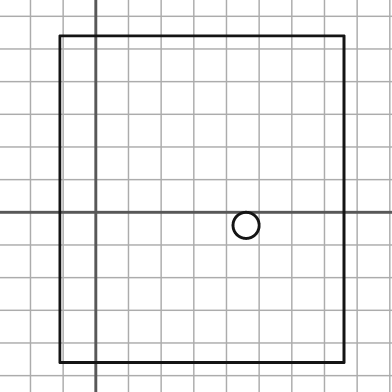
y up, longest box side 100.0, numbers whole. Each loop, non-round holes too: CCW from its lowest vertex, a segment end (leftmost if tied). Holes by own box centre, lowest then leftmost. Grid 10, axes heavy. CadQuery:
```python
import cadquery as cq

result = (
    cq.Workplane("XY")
    .moveTo(-11.0, -46.0)
    .lineTo(76.0, -46.0)
    .lineTo(76.0, 54.0)
    .lineTo(-11.0, 54.0)
    .close()
    .moveTo(46.0, -4.0)
    .circle(4.0)
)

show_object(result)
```